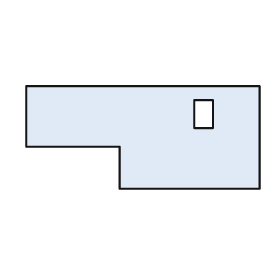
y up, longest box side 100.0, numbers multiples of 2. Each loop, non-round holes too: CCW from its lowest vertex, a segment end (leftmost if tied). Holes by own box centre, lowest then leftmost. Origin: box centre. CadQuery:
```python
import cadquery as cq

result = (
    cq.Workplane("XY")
    .moveTo(-10.0, -22.0)
    .lineTo(50.0, -22.0)
    .lineTo(50.0, 22.0)
    .lineTo(-50.0, 22.0)
    .lineTo(-50.0, -4.0)
    .lineTo(-10.0, -4.0)
    .close()
    .moveTo(22.0, 4.0)
    .lineTo(30.0, 4.0)
    .lineTo(30.0, 16.0)
    .lineTo(22.0, 16.0)
    .close()
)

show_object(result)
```